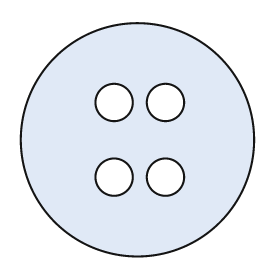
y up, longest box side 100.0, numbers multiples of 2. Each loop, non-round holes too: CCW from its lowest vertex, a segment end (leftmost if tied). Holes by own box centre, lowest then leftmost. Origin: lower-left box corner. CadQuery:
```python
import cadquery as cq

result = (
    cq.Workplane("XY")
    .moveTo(50.0, 50.0)
    .circle(50.0)
    .moveTo(40.0, 34.0)
    .circle(8.0)
    .moveTo(62.0, 34.0)
    .circle(8.0)
    .moveTo(40.0, 66.0)
    .circle(8.0)
    .moveTo(62.0, 66.0)
    .circle(8.0)
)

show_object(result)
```